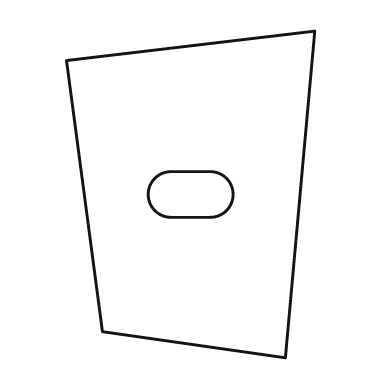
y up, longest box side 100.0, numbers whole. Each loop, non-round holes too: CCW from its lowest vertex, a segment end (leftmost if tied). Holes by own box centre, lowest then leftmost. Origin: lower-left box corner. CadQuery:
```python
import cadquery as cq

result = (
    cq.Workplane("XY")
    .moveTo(67.0, 0.0)
    .lineTo(76.0, 100.0)
    .lineTo(0.0, 91.0)
    .lineTo(11.0, 8.0)
    .close()
    .moveTo(32.0, 43.0)
    .lineTo(44.0, 43.0)
    .threePointArc((51.0, 50.0), (44.0, 57.0))
    .lineTo(32.0, 57.0)
    .threePointArc((25.0, 50.0), (32.0, 43.0))
    .close()
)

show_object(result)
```